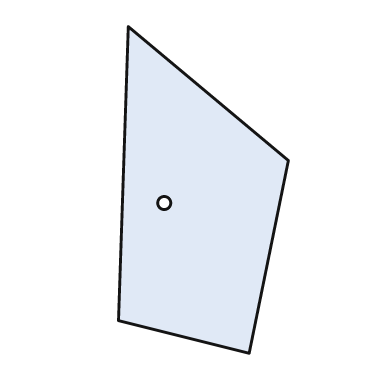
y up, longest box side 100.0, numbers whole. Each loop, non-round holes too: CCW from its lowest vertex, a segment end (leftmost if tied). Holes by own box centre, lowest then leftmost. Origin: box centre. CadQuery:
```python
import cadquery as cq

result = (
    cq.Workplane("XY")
    .moveTo(14.0, -50.0)
    .lineTo(26.0, 9.0)
    .lineTo(-23.0, 50.0)
    .lineTo(-26.0, -40.0)
    .close()
    .moveTo(-12.0, -4.0)
    .circle(2.0)
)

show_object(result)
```